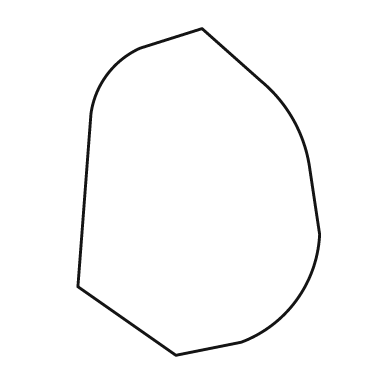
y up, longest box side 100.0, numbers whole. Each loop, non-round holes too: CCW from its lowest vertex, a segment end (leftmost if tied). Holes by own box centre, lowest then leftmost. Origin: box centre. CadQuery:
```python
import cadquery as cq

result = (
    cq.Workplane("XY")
    .moveTo(-7.0, -50.0)
    .lineTo(13.0, -46.0)
    .threePointArc((30.0, -33.0), (37.0, -13.0))
    .lineTo(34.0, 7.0)
    .threePointArc((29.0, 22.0), (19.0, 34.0))
    .lineTo(1.0, 50.0)
    .lineTo(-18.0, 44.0)
    .threePointArc((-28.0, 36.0), (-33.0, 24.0))
    .lineTo(-37.0, -29.0)
    .close()
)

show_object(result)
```